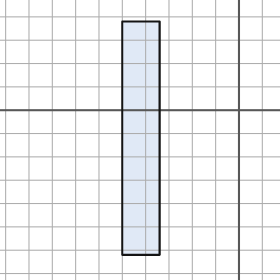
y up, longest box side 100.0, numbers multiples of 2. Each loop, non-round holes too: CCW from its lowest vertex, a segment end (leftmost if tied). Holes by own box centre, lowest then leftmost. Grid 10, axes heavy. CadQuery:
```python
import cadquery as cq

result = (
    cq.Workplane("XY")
    .moveTo(-50.0, -62.0)
    .lineTo(-34.0, -62.0)
    .lineTo(-34.0, 38.0)
    .lineTo(-50.0, 38.0)
    .close()
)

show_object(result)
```